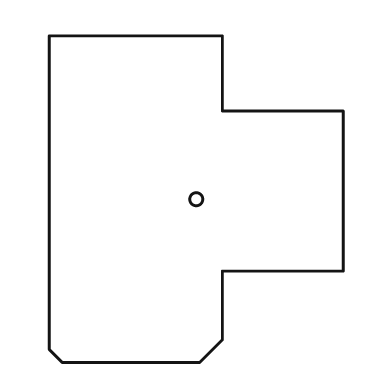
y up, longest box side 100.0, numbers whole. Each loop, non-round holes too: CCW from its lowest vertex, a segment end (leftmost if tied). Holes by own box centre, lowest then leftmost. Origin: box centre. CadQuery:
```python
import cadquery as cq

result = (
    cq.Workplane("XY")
    .moveTo(-41.0, -50.0)
    .lineTo(1.0, -50.0)
    .lineTo(8.0, -43.0)
    .lineTo(8.0, -22.0)
    .lineTo(45.0, -22.0)
    .lineTo(45.0, 27.0)
    .lineTo(8.0, 27.0)
    .lineTo(8.0, 50.0)
    .lineTo(-45.0, 50.0)
    .lineTo(-45.0, -46.0)
    .close()
    .moveTo(0.0, 0.0)
    .circle(2.0)
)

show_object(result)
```